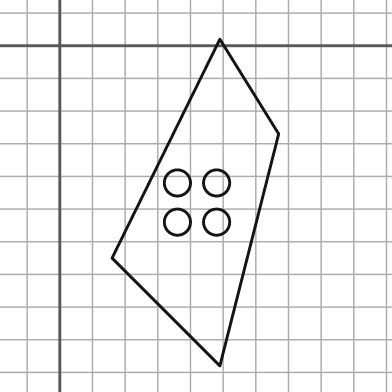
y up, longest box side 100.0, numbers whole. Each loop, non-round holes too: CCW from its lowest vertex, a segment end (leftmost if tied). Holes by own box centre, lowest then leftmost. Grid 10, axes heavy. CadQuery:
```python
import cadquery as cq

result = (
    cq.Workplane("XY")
    .moveTo(49.0, -98.0)
    .lineTo(67.0, -27.0)
    .lineTo(49.0, 2.0)
    .lineTo(16.0, -65.0)
    .close()
    .moveTo(36.0, -54.0)
    .circle(4.0)
    .moveTo(48.0, -54.0)
    .circle(4.0)
    .moveTo(36.0, -42.0)
    .circle(4.0)
    .moveTo(48.0, -42.0)
    .circle(4.0)
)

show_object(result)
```